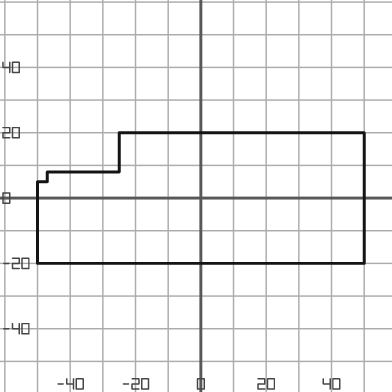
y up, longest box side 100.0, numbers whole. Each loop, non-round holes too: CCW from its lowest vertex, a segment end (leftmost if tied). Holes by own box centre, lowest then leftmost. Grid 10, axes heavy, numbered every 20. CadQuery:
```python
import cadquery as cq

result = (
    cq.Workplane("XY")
    .moveTo(-50.0, -20.0)
    .lineTo(50.0, -20.0)
    .lineTo(50.0, 20.0)
    .lineTo(-25.0, 20.0)
    .lineTo(-25.0, 8.0)
    .lineTo(-47.0, 8.0)
    .lineTo(-47.0, 5.0)
    .lineTo(-50.0, 5.0)
    .close()
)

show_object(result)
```